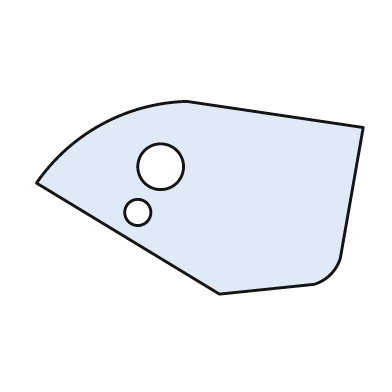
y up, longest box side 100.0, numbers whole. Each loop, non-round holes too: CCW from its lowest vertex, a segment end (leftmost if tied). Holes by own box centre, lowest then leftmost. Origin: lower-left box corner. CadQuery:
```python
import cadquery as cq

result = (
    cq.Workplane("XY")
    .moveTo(56.0, 0.0)
    .lineTo(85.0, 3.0)
    .threePointArc((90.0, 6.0), (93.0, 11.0))
    .lineTo(100.0, 51.0)
    .lineTo(46.0, 59.0)
    .threePointArc((20.0, 52.0), (0.0, 34.0))
    .close()
    .moveTo(31.0, 25.0)
    .circle(4.0)
    .moveTo(38.0, 39.0)
    .circle(7.0)
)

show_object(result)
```